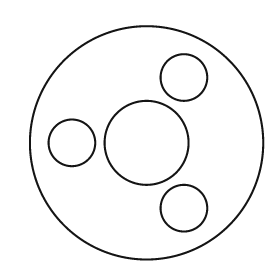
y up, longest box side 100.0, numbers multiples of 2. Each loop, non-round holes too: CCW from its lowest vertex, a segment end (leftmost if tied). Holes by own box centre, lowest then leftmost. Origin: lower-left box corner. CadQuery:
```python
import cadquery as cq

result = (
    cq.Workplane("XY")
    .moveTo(50.0, 50.0)
    .circle(50.0)
    .moveTo(66.0, 22.0)
    .circle(10.0)
    .moveTo(18.0, 50.0)
    .circle(10.0)
    .moveTo(50.0, 50.0)
    .circle(18.0)
    .moveTo(66.0, 78.0)
    .circle(10.0)
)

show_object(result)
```